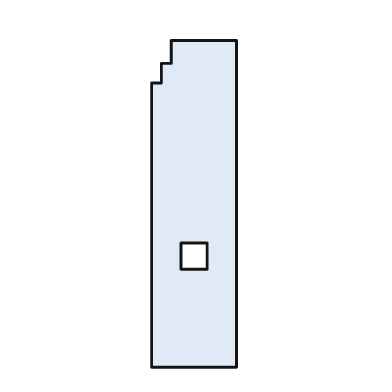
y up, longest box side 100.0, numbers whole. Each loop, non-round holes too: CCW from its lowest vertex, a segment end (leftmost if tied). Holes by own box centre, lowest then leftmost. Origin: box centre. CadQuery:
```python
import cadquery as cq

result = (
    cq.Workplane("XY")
    .moveTo(-13.0, -50.0)
    .lineTo(13.0, -50.0)
    .lineTo(13.0, 50.0)
    .lineTo(-7.0, 50.0)
    .lineTo(-7.0, 43.0)
    .lineTo(-10.0, 43.0)
    .lineTo(-10.0, 37.0)
    .lineTo(-13.0, 37.0)
    .close()
    .moveTo(-4.0, -20.0)
    .lineTo(4.0, -20.0)
    .lineTo(4.0, -12.0)
    .lineTo(-4.0, -12.0)
    .close()
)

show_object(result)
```